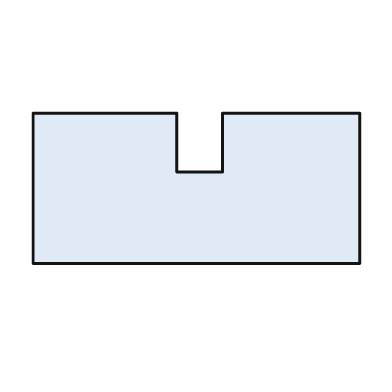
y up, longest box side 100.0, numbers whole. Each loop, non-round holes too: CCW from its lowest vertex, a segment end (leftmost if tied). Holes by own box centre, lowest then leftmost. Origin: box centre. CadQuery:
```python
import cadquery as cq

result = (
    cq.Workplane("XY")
    .moveTo(-50.0, -23.0)
    .lineTo(50.0, -23.0)
    .lineTo(50.0, 23.0)
    .lineTo(8.0, 23.0)
    .lineTo(8.0, 5.0)
    .lineTo(-6.0, 5.0)
    .lineTo(-6.0, 23.0)
    .lineTo(-50.0, 23.0)
    .close()
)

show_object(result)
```